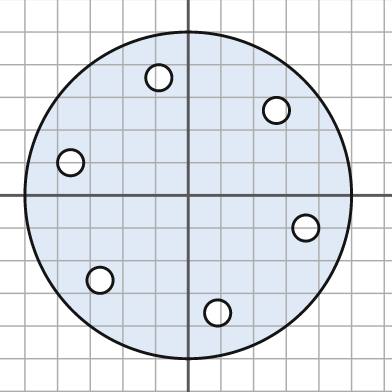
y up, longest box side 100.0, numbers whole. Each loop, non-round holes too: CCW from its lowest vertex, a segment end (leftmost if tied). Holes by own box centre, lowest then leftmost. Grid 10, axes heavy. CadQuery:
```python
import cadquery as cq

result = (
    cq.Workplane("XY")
    .moveTo(0.0, 0.0)
    .circle(50.0)
    .moveTo(9.0, -36.0)
    .circle(4.0)
    .moveTo(-27.0, -26.0)
    .circle(4.0)
    .moveTo(36.0, -10.0)
    .circle(4.0)
    .moveTo(-36.0, 10.0)
    .circle(4.0)
    .moveTo(27.0, 26.0)
    .circle(4.0)
    .moveTo(-9.0, 36.0)
    .circle(4.0)
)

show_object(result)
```